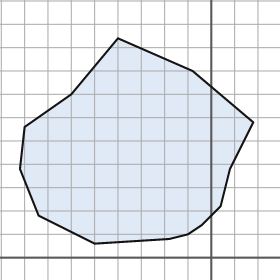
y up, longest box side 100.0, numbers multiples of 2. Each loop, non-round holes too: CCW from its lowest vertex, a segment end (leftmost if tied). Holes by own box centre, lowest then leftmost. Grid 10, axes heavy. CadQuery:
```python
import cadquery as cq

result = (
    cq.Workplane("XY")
    .moveTo(-50.0, 6.0)
    .lineTo(-18.0, 8.0)
    .lineTo(-10.0, 10.0)
    .lineTo(-4.0, 14.0)
    .lineTo(4.0, 22.0)
    .lineTo(8.0, 38.0)
    .lineTo(18.0, 58.0)
    .lineTo(-8.0, 80.0)
    .lineTo(-40.0, 94.0)
    .lineTo(-60.0, 70.0)
    .lineTo(-80.0, 56.0)
    .lineTo(-82.0, 38.0)
    .lineTo(-74.0, 18.0)
    .close()
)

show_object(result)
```